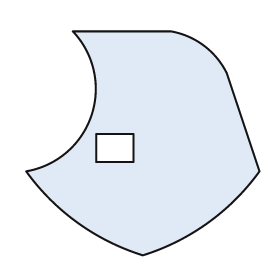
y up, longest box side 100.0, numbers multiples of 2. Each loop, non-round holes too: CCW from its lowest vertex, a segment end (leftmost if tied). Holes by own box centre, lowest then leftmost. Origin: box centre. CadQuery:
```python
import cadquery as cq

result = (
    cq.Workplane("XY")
    .moveTo(0.0, -48.0)
    .threePointArc((28.0, -34.0), (50.0, -12.0))
    .lineTo(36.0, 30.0)
    .threePointArc((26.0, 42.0), (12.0, 48.0))
    .lineTo(-30.0, 48.0)
    .threePointArc((-22.0, 12.0), (-50.0, -12.0))
    .threePointArc((-28.0, -34.0), (0.0, -48.0))
    .close()
    .moveTo(-20.0, -8.0)
    .lineTo(-4.0, -8.0)
    .lineTo(-4.0, 4.0)
    .lineTo(-20.0, 4.0)
    .close()
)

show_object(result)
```